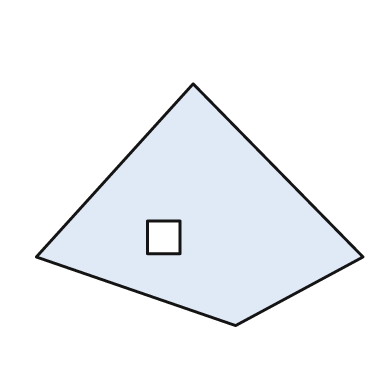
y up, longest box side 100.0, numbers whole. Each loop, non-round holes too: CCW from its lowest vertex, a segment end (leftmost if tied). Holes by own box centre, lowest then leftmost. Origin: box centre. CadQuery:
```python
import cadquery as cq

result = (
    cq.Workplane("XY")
    .moveTo(11.0, -37.0)
    .lineTo(50.0, -16.0)
    .lineTo(-2.0, 37.0)
    .lineTo(-50.0, -16.0)
    .close()
    .moveTo(-16.0, -15.0)
    .lineTo(-6.0, -15.0)
    .lineTo(-6.0, -5.0)
    .lineTo(-16.0, -5.0)
    .close()
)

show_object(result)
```